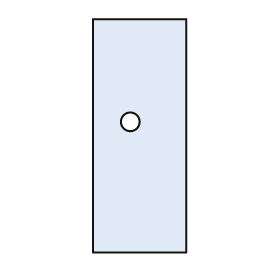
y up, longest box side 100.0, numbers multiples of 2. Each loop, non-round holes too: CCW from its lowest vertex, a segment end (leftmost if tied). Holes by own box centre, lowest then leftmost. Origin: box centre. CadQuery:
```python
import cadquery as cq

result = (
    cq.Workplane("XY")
    .moveTo(-20.0, -50.0)
    .lineTo(20.0, -50.0)
    .lineTo(20.0, 50.0)
    .lineTo(-20.0, 50.0)
    .close()
    .moveTo(-4.0, 6.0)
    .circle(4.0)
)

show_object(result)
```